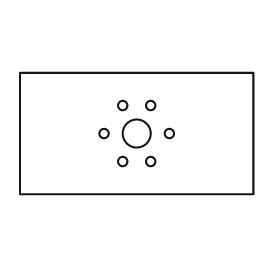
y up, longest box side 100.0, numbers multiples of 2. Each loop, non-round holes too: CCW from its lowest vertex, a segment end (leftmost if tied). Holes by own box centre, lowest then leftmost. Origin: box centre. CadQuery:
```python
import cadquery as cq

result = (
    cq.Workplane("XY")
    .moveTo(-50.0, -26.0)
    .lineTo(50.0, -26.0)
    .lineTo(50.0, 26.0)
    .lineTo(-50.0, 26.0)
    .close()
    .moveTo(-6.0, -12.0)
    .circle(2.0)
    .moveTo(6.0, -12.0)
    .circle(2.0)
    .moveTo(-14.0, 0.0)
    .circle(2.0)
    .moveTo(0.0, 0.0)
    .circle(6.0)
    .moveTo(14.0, 0.0)
    .circle(2.0)
    .moveTo(-6.0, 12.0)
    .circle(2.0)
    .moveTo(6.0, 12.0)
    .circle(2.0)
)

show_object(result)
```